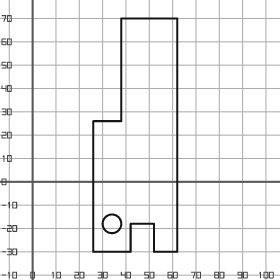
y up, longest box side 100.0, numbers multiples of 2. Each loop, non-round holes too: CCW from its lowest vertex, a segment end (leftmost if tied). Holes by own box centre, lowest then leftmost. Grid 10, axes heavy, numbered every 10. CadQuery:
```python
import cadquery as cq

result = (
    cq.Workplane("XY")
    .moveTo(26.0, -30.0)
    .lineTo(42.0, -30.0)
    .lineTo(42.0, -18.0)
    .lineTo(52.0, -18.0)
    .lineTo(52.0, -30.0)
    .lineTo(62.0, -30.0)
    .lineTo(62.0, 70.0)
    .lineTo(38.0, 70.0)
    .lineTo(38.0, 26.0)
    .lineTo(26.0, 26.0)
    .close()
    .moveTo(34.0, -18.0)
    .circle(4.0)
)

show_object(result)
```